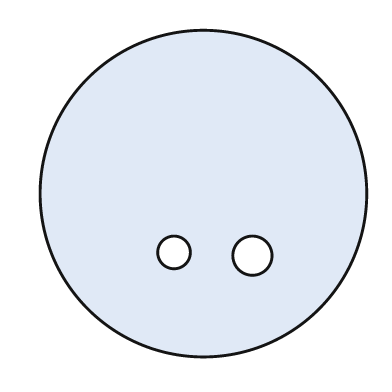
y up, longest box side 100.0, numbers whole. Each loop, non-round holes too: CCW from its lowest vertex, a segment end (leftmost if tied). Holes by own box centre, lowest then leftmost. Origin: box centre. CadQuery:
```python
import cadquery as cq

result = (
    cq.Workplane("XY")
    .moveTo(0.0, 0.0)
    .circle(50.0)
    .moveTo(15.0, -19.0)
    .circle(6.0)
    .moveTo(-9.0, -18.0)
    .circle(5.0)
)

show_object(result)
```